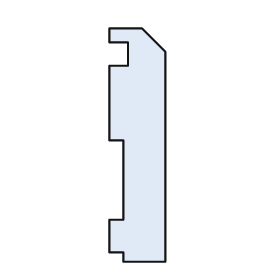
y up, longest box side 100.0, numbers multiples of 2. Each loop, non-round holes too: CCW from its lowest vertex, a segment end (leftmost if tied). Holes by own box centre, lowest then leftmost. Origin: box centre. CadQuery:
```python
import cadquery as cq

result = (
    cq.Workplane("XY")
    .moveTo(-6.0, -50.0)
    .lineTo(12.0, -50.0)
    .lineTo(12.0, 40.0)
    .lineTo(2.0, 50.0)
    .lineTo(-12.0, 50.0)
    .lineTo(-12.0, 44.0)
    .lineTo(-4.0, 44.0)
    .lineTo(-4.0, 34.0)
    .lineTo(-12.0, 34.0)
    .lineTo(-12.0, 2.0)
    .lineTo(-6.0, 2.0)
    .lineTo(-6.0, -32.0)
    .lineTo(-12.0, -32.0)
    .lineTo(-12.0, -46.0)
    .lineTo(-6.0, -46.0)
    .close()
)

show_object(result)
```